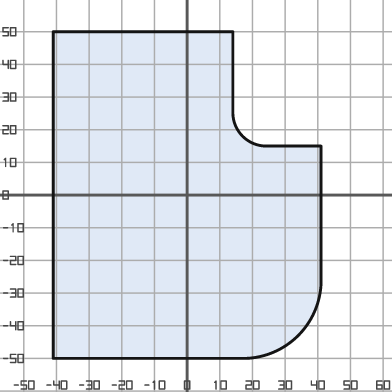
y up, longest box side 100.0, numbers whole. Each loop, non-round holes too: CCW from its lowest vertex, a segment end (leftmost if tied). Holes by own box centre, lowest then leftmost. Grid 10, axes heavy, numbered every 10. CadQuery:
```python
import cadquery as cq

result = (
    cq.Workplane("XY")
    .moveTo(-41.0, -50.0)
    .lineTo(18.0, -50.0)
    .threePointArc((34.0, -43.0), (41.0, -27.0))
    .lineTo(41.0, 15.0)
    .lineTo(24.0, 15.0)
    .threePointArc((17.0, 18.0), (14.0, 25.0))
    .lineTo(14.0, 50.0)
    .lineTo(-41.0, 50.0)
    .close()
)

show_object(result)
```